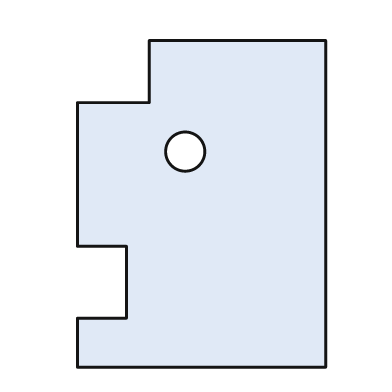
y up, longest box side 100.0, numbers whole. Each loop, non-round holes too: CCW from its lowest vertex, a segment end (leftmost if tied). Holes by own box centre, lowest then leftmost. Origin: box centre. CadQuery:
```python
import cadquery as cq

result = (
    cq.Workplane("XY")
    .moveTo(-38.0, -50.0)
    .lineTo(38.0, -50.0)
    .lineTo(38.0, 50.0)
    .lineTo(-16.0, 50.0)
    .lineTo(-16.0, 31.0)
    .lineTo(-38.0, 31.0)
    .lineTo(-38.0, -13.0)
    .lineTo(-23.0, -13.0)
    .lineTo(-23.0, -35.0)
    .lineTo(-38.0, -35.0)
    .close()
    .moveTo(-5.0, 16.0)
    .circle(6.0)
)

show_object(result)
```